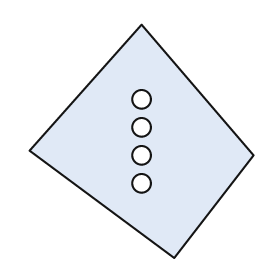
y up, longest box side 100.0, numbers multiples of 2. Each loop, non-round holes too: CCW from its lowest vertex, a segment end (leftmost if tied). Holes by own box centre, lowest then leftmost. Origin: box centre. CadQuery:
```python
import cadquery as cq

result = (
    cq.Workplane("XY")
    .moveTo(14.0, -50.0)
    .lineTo(48.0, -6.0)
    .lineTo(0.0, 50.0)
    .lineTo(-48.0, -4.0)
    .close()
    .moveTo(0.0, -18.0)
    .circle(4.0)
    .moveTo(0.0, -6.0)
    .circle(4.0)
    .moveTo(0.0, 6.0)
    .circle(4.0)
    .moveTo(0.0, 18.0)
    .circle(4.0)
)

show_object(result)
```